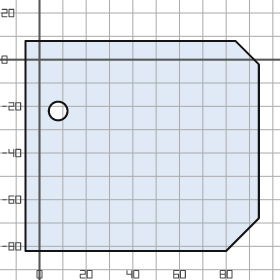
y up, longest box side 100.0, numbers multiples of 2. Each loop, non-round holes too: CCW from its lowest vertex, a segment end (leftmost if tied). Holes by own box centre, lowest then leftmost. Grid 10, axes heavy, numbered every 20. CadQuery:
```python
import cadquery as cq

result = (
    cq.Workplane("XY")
    .moveTo(-6.0, -82.0)
    .lineTo(80.0, -82.0)
    .lineTo(94.0, -68.0)
    .lineTo(94.0, -2.0)
    .lineTo(84.0, 8.0)
    .lineTo(-6.0, 8.0)
    .close()
    .moveTo(8.0, -22.0)
    .circle(4.0)
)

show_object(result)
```